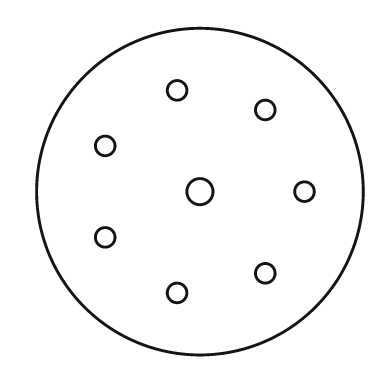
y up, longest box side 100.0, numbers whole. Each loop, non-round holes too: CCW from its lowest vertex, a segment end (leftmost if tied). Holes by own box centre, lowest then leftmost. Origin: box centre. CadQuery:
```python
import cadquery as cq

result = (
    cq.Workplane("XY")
    .moveTo(0.0, 0.0)
    .circle(50.0)
    .moveTo(-7.0, -31.0)
    .circle(3.0)
    .moveTo(20.0, -25.0)
    .circle(3.0)
    .moveTo(-29.0, -14.0)
    .circle(3.0)
    .moveTo(0.0, 0.0)
    .circle(4.0)
    .moveTo(32.0, 0.0)
    .circle(3.0)
    .moveTo(-29.0, 14.0)
    .circle(3.0)
    .moveTo(20.0, 25.0)
    .circle(3.0)
    .moveTo(-7.0, 31.0)
    .circle(3.0)
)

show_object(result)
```